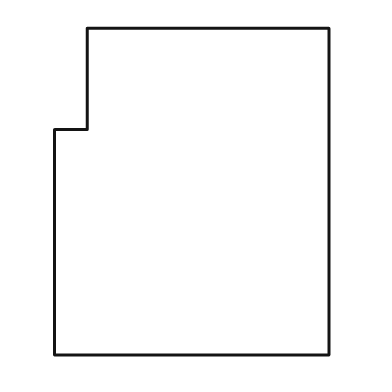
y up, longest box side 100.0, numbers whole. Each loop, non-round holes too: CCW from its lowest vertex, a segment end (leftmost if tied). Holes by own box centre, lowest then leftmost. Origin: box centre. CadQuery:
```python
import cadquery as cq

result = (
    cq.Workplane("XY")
    .moveTo(-42.0, -50.0)
    .lineTo(42.0, -50.0)
    .lineTo(42.0, 50.0)
    .lineTo(-32.0, 50.0)
    .lineTo(-32.0, 19.0)
    .lineTo(-42.0, 19.0)
    .close()
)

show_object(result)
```